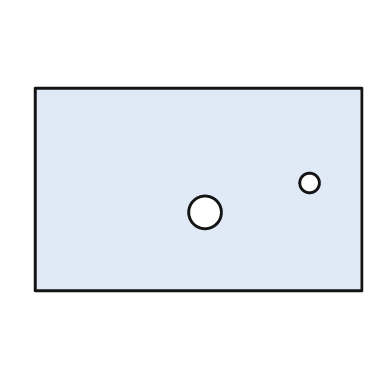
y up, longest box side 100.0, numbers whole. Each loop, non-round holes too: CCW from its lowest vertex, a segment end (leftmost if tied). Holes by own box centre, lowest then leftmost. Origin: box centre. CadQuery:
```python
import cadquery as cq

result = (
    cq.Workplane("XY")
    .moveTo(-50.0, -31.0)
    .lineTo(50.0, -31.0)
    .lineTo(50.0, 31.0)
    .lineTo(-50.0, 31.0)
    .close()
    .moveTo(2.0, -7.0)
    .circle(5.0)
    .moveTo(34.0, 2.0)
    .circle(3.0)
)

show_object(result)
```